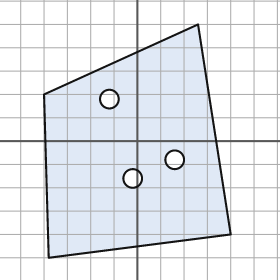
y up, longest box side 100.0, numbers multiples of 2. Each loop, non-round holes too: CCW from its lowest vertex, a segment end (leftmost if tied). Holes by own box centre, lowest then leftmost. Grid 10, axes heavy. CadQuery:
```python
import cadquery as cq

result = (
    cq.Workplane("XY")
    .moveTo(-38.0, -50.0)
    .lineTo(40.0, -40.0)
    .lineTo(26.0, 50.0)
    .lineTo(-40.0, 20.0)
    .close()
    .moveTo(-2.0, -16.0)
    .circle(4.0)
    .moveTo(16.0, -8.0)
    .circle(4.0)
    .moveTo(-12.0, 18.0)
    .circle(4.0)
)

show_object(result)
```